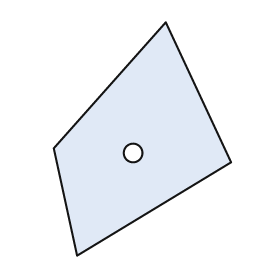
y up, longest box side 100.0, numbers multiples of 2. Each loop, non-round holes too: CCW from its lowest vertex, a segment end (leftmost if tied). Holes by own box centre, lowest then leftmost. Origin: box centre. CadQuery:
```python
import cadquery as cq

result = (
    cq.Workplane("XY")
    .moveTo(-28.0, -50.0)
    .lineTo(38.0, -10.0)
    .lineTo(10.0, 50.0)
    .lineTo(-38.0, -4.0)
    .close()
    .moveTo(-4.0, -6.0)
    .circle(4.0)
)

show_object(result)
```